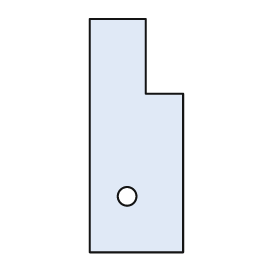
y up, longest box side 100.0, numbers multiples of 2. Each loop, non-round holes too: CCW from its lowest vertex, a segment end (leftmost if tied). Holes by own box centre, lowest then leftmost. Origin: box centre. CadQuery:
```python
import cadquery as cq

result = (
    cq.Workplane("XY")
    .moveTo(-20.0, -50.0)
    .lineTo(20.0, -50.0)
    .lineTo(20.0, 18.0)
    .lineTo(4.0, 18.0)
    .lineTo(4.0, 50.0)
    .lineTo(-20.0, 50.0)
    .close()
    .moveTo(-4.0, -26.0)
    .circle(4.0)
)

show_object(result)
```